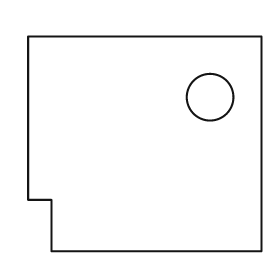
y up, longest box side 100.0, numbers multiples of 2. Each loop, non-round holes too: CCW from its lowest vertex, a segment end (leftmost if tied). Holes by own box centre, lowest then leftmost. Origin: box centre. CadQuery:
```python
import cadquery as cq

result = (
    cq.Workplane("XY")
    .moveTo(-40.0, -46.0)
    .lineTo(50.0, -46.0)
    .lineTo(50.0, 46.0)
    .lineTo(-50.0, 46.0)
    .lineTo(-50.0, -24.0)
    .lineTo(-40.0, -24.0)
    .close()
    .moveTo(28.0, 20.0)
    .circle(10.0)
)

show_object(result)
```